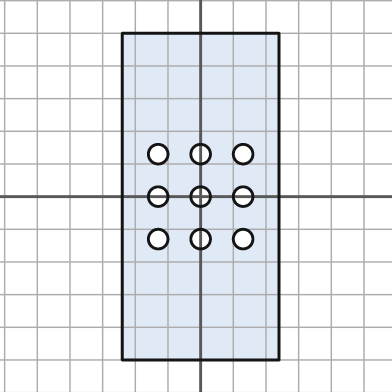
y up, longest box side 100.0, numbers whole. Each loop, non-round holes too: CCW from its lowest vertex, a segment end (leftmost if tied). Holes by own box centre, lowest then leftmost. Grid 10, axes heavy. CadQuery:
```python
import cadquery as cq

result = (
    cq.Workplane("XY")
    .moveTo(-24.0, -50.0)
    .lineTo(24.0, -50.0)
    .lineTo(24.0, 50.0)
    .lineTo(-24.0, 50.0)
    .close()
    .moveTo(-13.0, -13.0)
    .circle(3.0)
    .moveTo(0.0, -13.0)
    .circle(3.0)
    .moveTo(13.0, -13.0)
    .circle(3.0)
    .moveTo(-13.0, 0.0)
    .circle(3.0)
    .moveTo(0.0, 0.0)
    .circle(3.0)
    .moveTo(13.0, 0.0)
    .circle(3.0)
    .moveTo(-13.0, 13.0)
    .circle(3.0)
    .moveTo(0.0, 13.0)
    .circle(3.0)
    .moveTo(13.0, 13.0)
    .circle(3.0)
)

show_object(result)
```